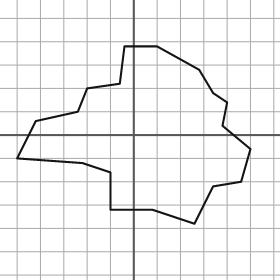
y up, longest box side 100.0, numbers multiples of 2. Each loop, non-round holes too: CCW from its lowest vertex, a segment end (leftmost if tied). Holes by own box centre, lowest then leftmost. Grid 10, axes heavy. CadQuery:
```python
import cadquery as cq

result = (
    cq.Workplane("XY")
    .moveTo(26.0, -38.0)
    .lineTo(34.0, -22.0)
    .lineTo(46.0, -20.0)
    .lineTo(50.0, -6.0)
    .lineTo(38.0, 4.0)
    .lineTo(40.0, 14.0)
    .lineTo(34.0, 18.0)
    .lineTo(28.0, 28.0)
    .lineTo(10.0, 38.0)
    .lineTo(-4.0, 38.0)
    .lineTo(-6.0, 22.0)
    .lineTo(-20.0, 20.0)
    .lineTo(-24.0, 10.0)
    .lineTo(-42.0, 6.0)
    .lineTo(-50.0, -10.0)
    .lineTo(-22.0, -12.0)
    .lineTo(-10.0, -16.0)
    .lineTo(-10.0, -32.0)
    .lineTo(8.0, -32.0)
    .close()
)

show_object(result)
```